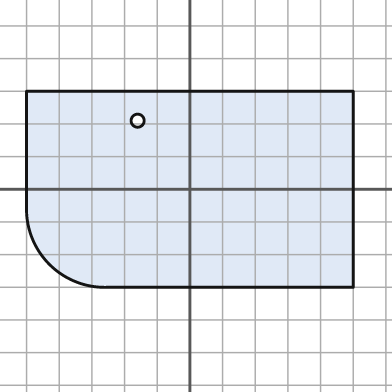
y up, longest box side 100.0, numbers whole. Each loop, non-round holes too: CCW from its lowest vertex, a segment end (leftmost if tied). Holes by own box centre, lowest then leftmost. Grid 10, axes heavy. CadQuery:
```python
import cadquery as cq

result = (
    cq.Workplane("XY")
    .moveTo(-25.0, -30.0)
    .lineTo(50.0, -30.0)
    .lineTo(50.0, 30.0)
    .lineTo(-50.0, 30.0)
    .lineTo(-50.0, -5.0)
    .threePointArc((-43.0, -23.0), (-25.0, -30.0))
    .close()
    .moveTo(-16.0, 21.0)
    .circle(2.0)
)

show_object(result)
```